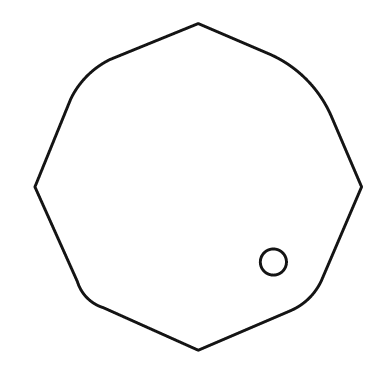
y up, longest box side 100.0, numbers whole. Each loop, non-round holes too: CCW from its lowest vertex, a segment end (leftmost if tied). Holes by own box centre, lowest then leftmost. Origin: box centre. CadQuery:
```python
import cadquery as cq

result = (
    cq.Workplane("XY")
    .moveTo(0.0, -50.0)
    .lineTo(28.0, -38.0)
    .threePointArc((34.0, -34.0), (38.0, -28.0))
    .lineTo(50.0, 0.0)
    .lineTo(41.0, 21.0)
    .threePointArc((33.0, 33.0), (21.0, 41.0))
    .lineTo(0.0, 50.0)
    .lineTo(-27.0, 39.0)
    .threePointArc((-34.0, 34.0), (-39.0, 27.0))
    .lineTo(-50.0, 0.0)
    .lineTo(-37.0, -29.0)
    .threePointArc((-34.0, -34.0), (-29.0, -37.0))
    .close()
    .moveTo(23.0, -23.0)
    .circle(4.0)
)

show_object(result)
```